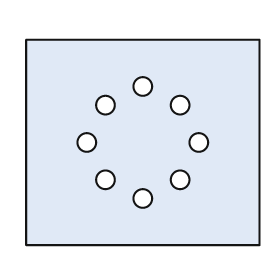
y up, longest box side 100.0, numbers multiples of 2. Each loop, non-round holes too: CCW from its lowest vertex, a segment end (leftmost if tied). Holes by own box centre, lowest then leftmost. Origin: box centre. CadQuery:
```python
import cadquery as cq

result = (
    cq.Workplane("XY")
    .moveTo(-50.0, -44.0)
    .lineTo(50.0, -44.0)
    .lineTo(50.0, 44.0)
    .lineTo(-50.0, 44.0)
    .close()
    .moveTo(0.0, -24.0)
    .circle(4.0)
    .moveTo(-16.0, -16.0)
    .circle(4.0)
    .moveTo(16.0, -16.0)
    .circle(4.0)
    .moveTo(-24.0, 0.0)
    .circle(4.0)
    .moveTo(24.0, 0.0)
    .circle(4.0)
    .moveTo(-16.0, 16.0)
    .circle(4.0)
    .moveTo(16.0, 16.0)
    .circle(4.0)
    .moveTo(0.0, 24.0)
    .circle(4.0)
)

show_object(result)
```